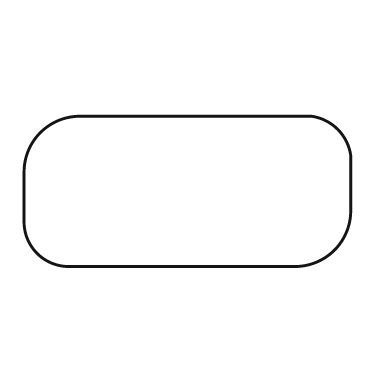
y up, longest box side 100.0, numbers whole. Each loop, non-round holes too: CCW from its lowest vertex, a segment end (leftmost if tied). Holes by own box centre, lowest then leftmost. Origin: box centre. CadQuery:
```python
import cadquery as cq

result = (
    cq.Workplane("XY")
    .moveTo(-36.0, -23.0)
    .lineTo(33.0, -23.0)
    .threePointArc((45.0, -18.0), (50.0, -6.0))
    .lineTo(50.0, 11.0)
    .threePointArc((46.0, 19.0), (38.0, 23.0))
    .lineTo(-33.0, 23.0)
    .threePointArc((-45.0, 18.0), (-50.0, 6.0))
    .lineTo(-50.0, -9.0)
    .threePointArc((-46.0, -19.0), (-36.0, -23.0))
    .close()
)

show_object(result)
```